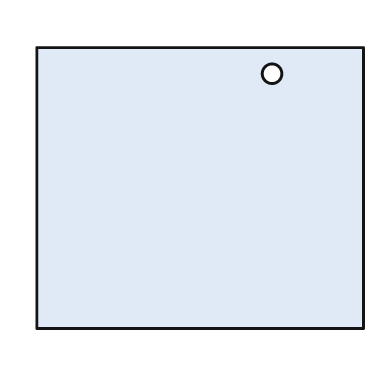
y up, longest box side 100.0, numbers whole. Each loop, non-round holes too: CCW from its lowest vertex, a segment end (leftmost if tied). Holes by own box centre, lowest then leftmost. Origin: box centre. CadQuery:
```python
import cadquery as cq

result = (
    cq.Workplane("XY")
    .moveTo(-50.0, -43.0)
    .lineTo(50.0, -43.0)
    .lineTo(50.0, 43.0)
    .lineTo(-50.0, 43.0)
    .close()
    .moveTo(22.0, 35.0)
    .circle(3.0)
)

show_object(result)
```